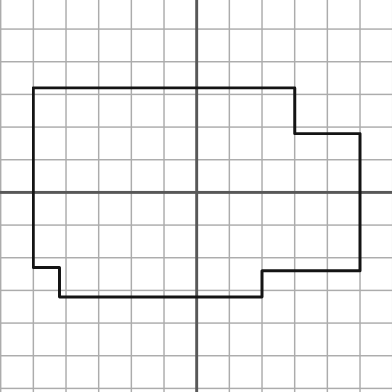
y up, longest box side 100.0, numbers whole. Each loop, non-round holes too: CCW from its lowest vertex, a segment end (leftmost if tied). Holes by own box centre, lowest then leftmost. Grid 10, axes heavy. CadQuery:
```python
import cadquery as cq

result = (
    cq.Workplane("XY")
    .moveTo(-42.0, -32.0)
    .lineTo(20.0, -32.0)
    .lineTo(20.0, -24.0)
    .lineTo(50.0, -24.0)
    .lineTo(50.0, 18.0)
    .lineTo(30.0, 18.0)
    .lineTo(30.0, 32.0)
    .lineTo(-50.0, 32.0)
    .lineTo(-50.0, -23.0)
    .lineTo(-42.0, -23.0)
    .close()
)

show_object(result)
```